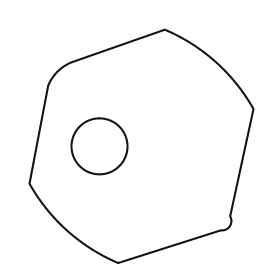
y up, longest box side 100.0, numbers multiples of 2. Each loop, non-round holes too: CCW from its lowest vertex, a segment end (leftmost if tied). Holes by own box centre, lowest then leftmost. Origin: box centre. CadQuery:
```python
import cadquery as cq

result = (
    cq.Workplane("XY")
    .moveTo(-10.0, -50.0)
    .lineTo(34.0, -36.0)
    .threePointArc((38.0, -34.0), (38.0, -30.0))
    .lineTo(48.0, 16.0)
    .threePointArc((32.0, 36.0), (10.0, 50.0))
    .lineTo(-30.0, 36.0)
    .threePointArc((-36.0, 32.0), (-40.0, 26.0))
    .lineTo(-48.0, -16.0)
    .threePointArc((-32.0, -36.0), (-10.0, -50.0))
    .close()
    .moveTo(-18.0, 0.0)
    .circle(12.0)
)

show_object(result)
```